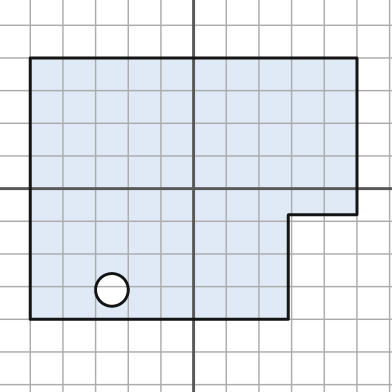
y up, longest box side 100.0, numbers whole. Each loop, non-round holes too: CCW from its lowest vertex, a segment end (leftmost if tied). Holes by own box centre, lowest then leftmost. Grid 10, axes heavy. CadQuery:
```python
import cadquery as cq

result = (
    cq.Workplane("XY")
    .moveTo(-50.0, -40.0)
    .lineTo(29.0, -40.0)
    .lineTo(29.0, -8.0)
    .lineTo(50.0, -8.0)
    .lineTo(50.0, 40.0)
    .lineTo(-50.0, 40.0)
    .close()
    .moveTo(-25.0, -31.0)
    .circle(5.0)
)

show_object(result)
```